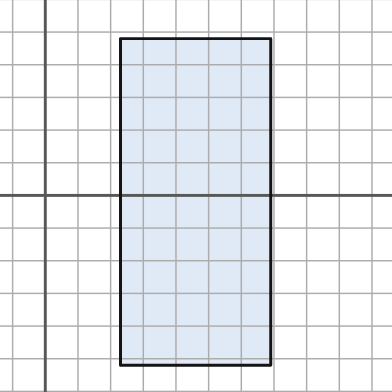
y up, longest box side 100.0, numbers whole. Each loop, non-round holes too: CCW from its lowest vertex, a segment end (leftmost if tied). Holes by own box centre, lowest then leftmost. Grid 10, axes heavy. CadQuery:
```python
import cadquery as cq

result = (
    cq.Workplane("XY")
    .moveTo(23.0, -52.0)
    .lineTo(69.0, -52.0)
    .lineTo(69.0, 48.0)
    .lineTo(23.0, 48.0)
    .close()
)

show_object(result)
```